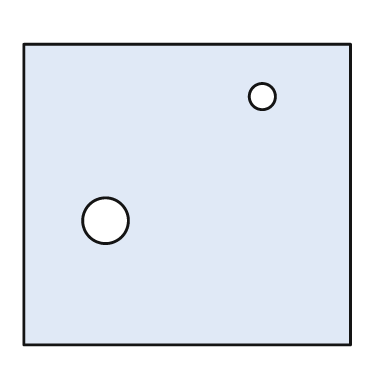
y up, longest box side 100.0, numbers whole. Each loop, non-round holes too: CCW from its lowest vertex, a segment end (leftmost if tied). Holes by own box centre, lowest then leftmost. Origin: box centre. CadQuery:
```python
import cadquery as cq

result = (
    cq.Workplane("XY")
    .moveTo(-50.0, -46.0)
    .lineTo(50.0, -46.0)
    .lineTo(50.0, 46.0)
    .lineTo(-50.0, 46.0)
    .close()
    .moveTo(-25.0, -8.0)
    .circle(7.0)
    .moveTo(23.0, 30.0)
    .circle(4.0)
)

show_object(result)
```